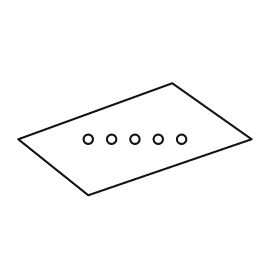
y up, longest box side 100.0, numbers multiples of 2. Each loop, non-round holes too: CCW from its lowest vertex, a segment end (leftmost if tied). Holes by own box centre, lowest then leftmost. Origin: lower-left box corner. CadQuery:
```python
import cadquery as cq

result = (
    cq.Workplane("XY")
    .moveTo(30.0, 0.0)
    .lineTo(100.0, 24.0)
    .lineTo(66.0, 48.0)
    .lineTo(0.0, 24.0)
    .close()
    .moveTo(30.0, 24.0)
    .circle(2.0)
    .moveTo(40.0, 24.0)
    .circle(2.0)
    .moveTo(50.0, 24.0)
    .circle(2.0)
    .moveTo(60.0, 24.0)
    .circle(2.0)
    .moveTo(70.0, 24.0)
    .circle(2.0)
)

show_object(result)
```